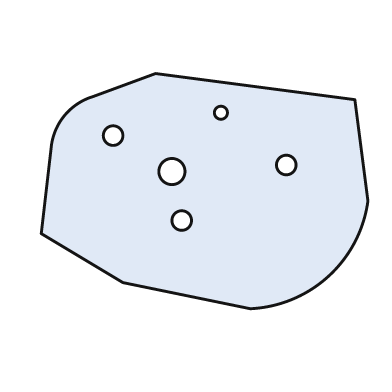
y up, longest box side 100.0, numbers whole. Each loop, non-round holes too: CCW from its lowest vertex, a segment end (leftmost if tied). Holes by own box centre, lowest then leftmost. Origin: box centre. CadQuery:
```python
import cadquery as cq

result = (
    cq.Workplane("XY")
    .moveTo(14.0, -36.0)
    .threePointArc((38.0, -26.0), (50.0, -3.0))
    .lineTo(46.0, 28.0)
    .lineTo(-15.0, 36.0)
    .lineTo(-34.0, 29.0)
    .threePointArc((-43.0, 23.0), (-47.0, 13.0))
    .lineTo(-50.0, -13.0)
    .lineTo(-25.0, -28.0)
    .close()
    .moveTo(-7.0, -9.0)
    .circle(3.0)
    .moveTo(-10.0, 6.0)
    .circle(4.0)
    .moveTo(25.0, 8.0)
    .circle(3.0)
    .moveTo(-28.0, 17.0)
    .circle(3.0)
    .moveTo(5.0, 24.0)
    .circle(2.0)
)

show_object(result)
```